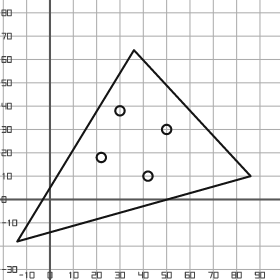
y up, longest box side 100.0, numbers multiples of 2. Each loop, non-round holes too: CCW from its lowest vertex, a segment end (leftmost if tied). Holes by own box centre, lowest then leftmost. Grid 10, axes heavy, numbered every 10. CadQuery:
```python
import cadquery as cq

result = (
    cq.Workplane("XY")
    .moveTo(-14.0, -18.0)
    .lineTo(86.0, 10.0)
    .lineTo(36.0, 64.0)
    .close()
    .moveTo(42.0, 10.0)
    .circle(2.0)
    .moveTo(22.0, 18.0)
    .circle(2.0)
    .moveTo(50.0, 30.0)
    .circle(2.0)
    .moveTo(30.0, 38.0)
    .circle(2.0)
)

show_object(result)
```